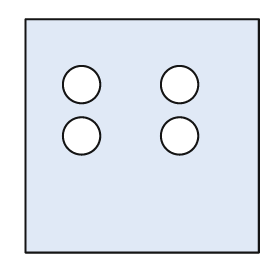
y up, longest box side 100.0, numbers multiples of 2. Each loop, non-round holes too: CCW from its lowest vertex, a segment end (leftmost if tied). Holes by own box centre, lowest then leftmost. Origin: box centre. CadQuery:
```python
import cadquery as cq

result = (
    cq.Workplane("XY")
    .moveTo(-50.0, -50.0)
    .lineTo(50.0, -50.0)
    .lineTo(50.0, 50.0)
    .lineTo(-50.0, 50.0)
    .close()
    .moveTo(-26.0, 0.0)
    .circle(8.0)
    .moveTo(16.0, 0.0)
    .circle(8.0)
    .moveTo(-26.0, 22.0)
    .circle(8.0)
    .moveTo(16.0, 22.0)
    .circle(8.0)
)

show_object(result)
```